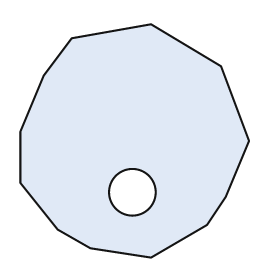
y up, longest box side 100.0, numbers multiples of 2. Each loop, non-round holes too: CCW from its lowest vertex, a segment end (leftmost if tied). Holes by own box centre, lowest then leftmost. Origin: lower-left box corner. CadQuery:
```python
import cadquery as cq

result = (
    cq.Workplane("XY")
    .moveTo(56.0, 0.0)
    .lineTo(80.0, 14.0)
    .lineTo(88.0, 26.0)
    .lineTo(98.0, 50.0)
    .lineTo(86.0, 82.0)
    .lineTo(56.0, 100.0)
    .lineTo(22.0, 94.0)
    .lineTo(10.0, 78.0)
    .lineTo(0.0, 54.0)
    .lineTo(0.0, 32.0)
    .lineTo(16.0, 12.0)
    .lineTo(30.0, 4.0)
    .close()
    .moveTo(48.0, 28.0)
    .circle(10.0)
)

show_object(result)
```